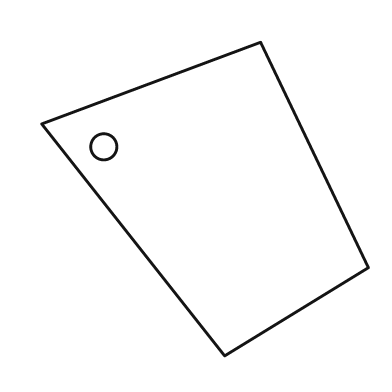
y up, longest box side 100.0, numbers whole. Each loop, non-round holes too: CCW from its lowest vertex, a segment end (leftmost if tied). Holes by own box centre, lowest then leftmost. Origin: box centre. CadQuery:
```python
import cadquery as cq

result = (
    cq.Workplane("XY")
    .moveTo(6.0, -48.0)
    .lineTo(50.0, -21.0)
    .lineTo(17.0, 48.0)
    .lineTo(-50.0, 23.0)
    .close()
    .moveTo(-31.0, 16.0)
    .circle(4.0)
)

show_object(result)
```